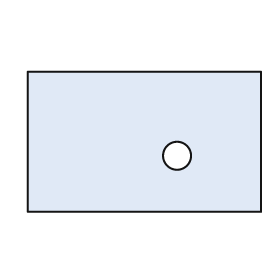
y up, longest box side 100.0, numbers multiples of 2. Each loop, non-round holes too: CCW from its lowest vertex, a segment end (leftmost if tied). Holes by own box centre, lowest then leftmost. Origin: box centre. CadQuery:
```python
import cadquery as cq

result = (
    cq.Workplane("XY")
    .moveTo(-50.0, -30.0)
    .lineTo(50.0, -30.0)
    .lineTo(50.0, 30.0)
    .lineTo(-50.0, 30.0)
    .close()
    .moveTo(14.0, -6.0)
    .circle(6.0)
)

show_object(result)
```